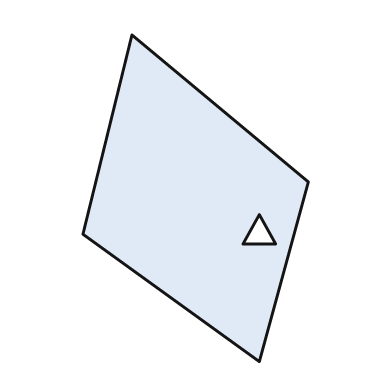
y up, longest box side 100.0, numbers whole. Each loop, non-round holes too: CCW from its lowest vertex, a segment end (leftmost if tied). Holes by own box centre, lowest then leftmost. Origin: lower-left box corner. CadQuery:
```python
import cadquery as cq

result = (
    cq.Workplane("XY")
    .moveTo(54.0, 0.0)
    .lineTo(69.0, 55.0)
    .lineTo(15.0, 100.0)
    .lineTo(0.0, 39.0)
    .close()
    .moveTo(49.0, 36.0)
    .lineTo(59.0, 36.0)
    .lineTo(54.0, 45.0)
    .close()
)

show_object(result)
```